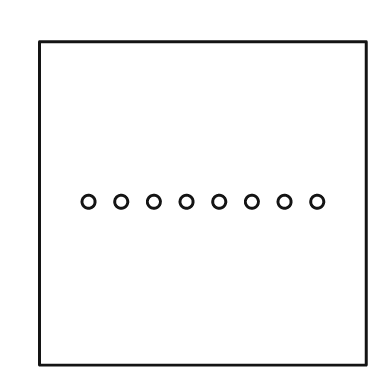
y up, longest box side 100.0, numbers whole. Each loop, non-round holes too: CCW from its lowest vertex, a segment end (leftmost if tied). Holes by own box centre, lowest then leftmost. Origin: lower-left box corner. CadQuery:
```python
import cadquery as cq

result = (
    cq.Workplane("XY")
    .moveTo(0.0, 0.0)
    .lineTo(100.0, 0.0)
    .lineTo(100.0, 99.0)
    .lineTo(0.0, 99.0)
    .close()
    .moveTo(15.0, 50.0)
    .circle(2.0)
    .moveTo(25.0, 50.0)
    .circle(2.0)
    .moveTo(35.0, 50.0)
    .circle(2.0)
    .moveTo(45.0, 50.0)
    .circle(2.0)
    .moveTo(55.0, 50.0)
    .circle(2.0)
    .moveTo(65.0, 50.0)
    .circle(2.0)
    .moveTo(75.0, 50.0)
    .circle(2.0)
    .moveTo(85.0, 50.0)
    .circle(2.0)
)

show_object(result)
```